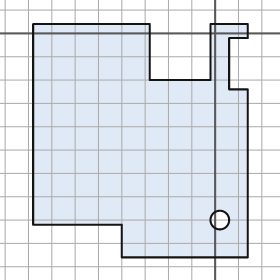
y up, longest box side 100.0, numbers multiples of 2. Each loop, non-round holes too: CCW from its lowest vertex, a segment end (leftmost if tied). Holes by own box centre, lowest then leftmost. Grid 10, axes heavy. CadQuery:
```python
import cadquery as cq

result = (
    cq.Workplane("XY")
    .moveTo(-40.0, -96.0)
    .lineTo(14.0, -96.0)
    .lineTo(14.0, -24.0)
    .lineTo(6.0, -24.0)
    .lineTo(6.0, -2.0)
    .lineTo(14.0, -2.0)
    .lineTo(14.0, 4.0)
    .lineTo(-2.0, 4.0)
    .lineTo(-2.0, -20.0)
    .lineTo(-28.0, -20.0)
    .lineTo(-28.0, 4.0)
    .lineTo(-78.0, 4.0)
    .lineTo(-78.0, -82.0)
    .lineTo(-40.0, -82.0)
    .close()
    .moveTo(2.0, -80.0)
    .circle(4.0)
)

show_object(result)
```